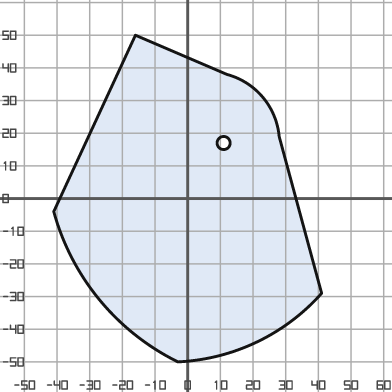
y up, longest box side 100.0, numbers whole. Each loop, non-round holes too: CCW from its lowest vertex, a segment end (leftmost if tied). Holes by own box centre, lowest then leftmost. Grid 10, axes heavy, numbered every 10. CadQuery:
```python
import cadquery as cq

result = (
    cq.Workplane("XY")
    .moveTo(-3.0, -50.0)
    .threePointArc((21.0, -44.0), (41.0, -29.0))
    .lineTo(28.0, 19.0)
    .threePointArc((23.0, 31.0), (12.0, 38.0))
    .lineTo(-16.0, 50.0)
    .lineTo(-41.0, -4.0)
    .threePointArc((-27.0, -31.0), (-3.0, -50.0))
    .close()
    .moveTo(11.0, 17.0)
    .circle(2.0)
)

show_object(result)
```